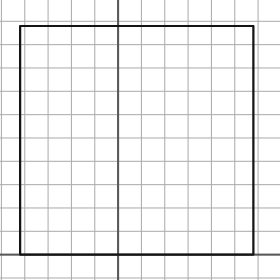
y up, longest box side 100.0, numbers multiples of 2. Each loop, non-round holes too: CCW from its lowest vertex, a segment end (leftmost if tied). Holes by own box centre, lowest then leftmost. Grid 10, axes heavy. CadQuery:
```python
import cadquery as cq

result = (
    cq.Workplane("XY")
    .moveTo(-42.0, 0.0)
    .lineTo(58.0, 0.0)
    .lineTo(58.0, 98.0)
    .lineTo(-42.0, 98.0)
    .close()
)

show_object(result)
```